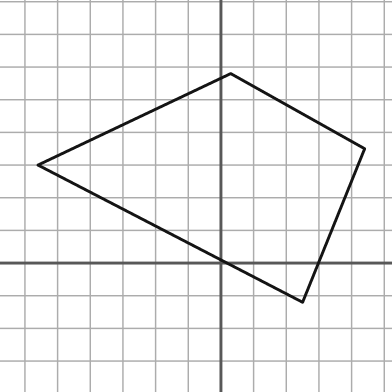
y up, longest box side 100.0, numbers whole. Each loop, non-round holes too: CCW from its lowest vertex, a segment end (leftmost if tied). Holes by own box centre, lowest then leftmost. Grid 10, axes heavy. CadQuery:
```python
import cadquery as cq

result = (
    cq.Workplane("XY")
    .moveTo(25.0, -12.0)
    .lineTo(44.0, 35.0)
    .lineTo(3.0, 58.0)
    .lineTo(-56.0, 30.0)
    .close()
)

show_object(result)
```